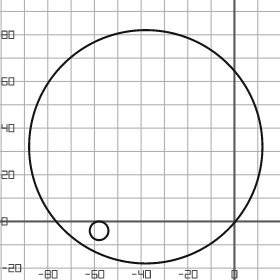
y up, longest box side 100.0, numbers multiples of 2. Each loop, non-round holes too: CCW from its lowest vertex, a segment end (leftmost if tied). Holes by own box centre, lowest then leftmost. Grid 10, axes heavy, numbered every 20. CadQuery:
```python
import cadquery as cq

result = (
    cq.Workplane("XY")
    .moveTo(-38.0, 32.0)
    .circle(50.0)
    .moveTo(-58.0, -4.0)
    .circle(4.0)
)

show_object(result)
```